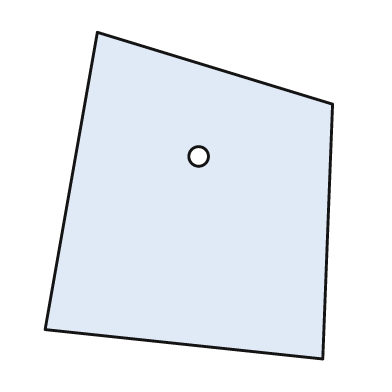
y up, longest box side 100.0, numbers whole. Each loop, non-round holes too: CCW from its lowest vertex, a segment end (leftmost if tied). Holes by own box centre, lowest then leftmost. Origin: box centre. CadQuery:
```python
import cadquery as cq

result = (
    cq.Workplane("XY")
    .moveTo(41.0, -50.0)
    .lineTo(44.0, 28.0)
    .lineTo(-28.0, 50.0)
    .lineTo(-44.0, -41.0)
    .close()
    .moveTo(3.0, 12.0)
    .circle(3.0)
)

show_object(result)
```